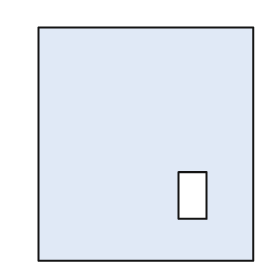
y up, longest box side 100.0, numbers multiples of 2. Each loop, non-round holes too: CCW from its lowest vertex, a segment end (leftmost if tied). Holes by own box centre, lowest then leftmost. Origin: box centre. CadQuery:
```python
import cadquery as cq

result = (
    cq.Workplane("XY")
    .moveTo(-46.0, -50.0)
    .lineTo(46.0, -50.0)
    .lineTo(46.0, 50.0)
    .lineTo(-46.0, 50.0)
    .close()
    .moveTo(14.0, -32.0)
    .lineTo(26.0, -32.0)
    .lineTo(26.0, -12.0)
    .lineTo(14.0, -12.0)
    .close()
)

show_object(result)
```